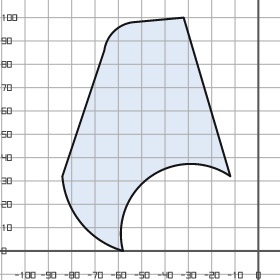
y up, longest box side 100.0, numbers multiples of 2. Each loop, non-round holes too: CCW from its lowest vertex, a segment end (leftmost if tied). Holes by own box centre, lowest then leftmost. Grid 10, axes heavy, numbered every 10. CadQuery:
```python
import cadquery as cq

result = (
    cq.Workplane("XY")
    .moveTo(-58.0, 0.0)
    .threePointArc((-46.0, 32.0), (-12.0, 32.0))
    .lineTo(-32.0, 100.0)
    .lineTo(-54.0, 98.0)
    .threePointArc((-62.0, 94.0), (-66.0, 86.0))
    .lineTo(-84.0, 32.0)
    .threePointArc((-76.0, 12.0), (-58.0, 0.0))
    .close()
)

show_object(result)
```